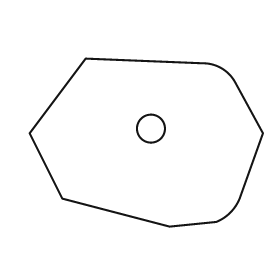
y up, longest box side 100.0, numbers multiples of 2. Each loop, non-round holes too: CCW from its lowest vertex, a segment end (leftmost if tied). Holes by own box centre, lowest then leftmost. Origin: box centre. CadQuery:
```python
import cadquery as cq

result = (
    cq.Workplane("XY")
    .moveTo(10.0, -36.0)
    .lineTo(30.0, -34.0)
    .threePointArc((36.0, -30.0), (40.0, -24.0))
    .lineTo(50.0, 4.0)
    .lineTo(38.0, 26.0)
    .threePointArc((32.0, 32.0), (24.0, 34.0))
    .lineTo(-26.0, 36.0)
    .lineTo(-50.0, 4.0)
    .lineTo(-36.0, -24.0)
    .close()
    .moveTo(2.0, 6.0)
    .circle(6.0)
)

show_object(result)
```